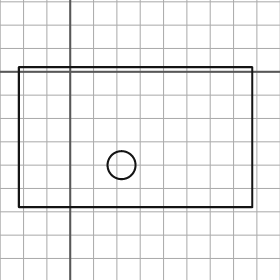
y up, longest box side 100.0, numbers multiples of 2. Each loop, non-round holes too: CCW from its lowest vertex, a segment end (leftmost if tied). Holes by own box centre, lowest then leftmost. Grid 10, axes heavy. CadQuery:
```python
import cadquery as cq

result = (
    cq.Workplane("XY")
    .moveTo(-22.0, -58.0)
    .lineTo(78.0, -58.0)
    .lineTo(78.0, 2.0)
    .lineTo(-22.0, 2.0)
    .close()
    .moveTo(22.0, -40.0)
    .circle(6.0)
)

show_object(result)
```